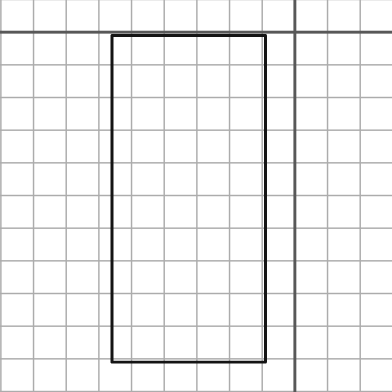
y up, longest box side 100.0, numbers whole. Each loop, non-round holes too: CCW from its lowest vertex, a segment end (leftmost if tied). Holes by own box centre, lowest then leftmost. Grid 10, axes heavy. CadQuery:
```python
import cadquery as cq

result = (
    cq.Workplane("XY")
    .moveTo(-56.0, -101.0)
    .lineTo(-9.0, -101.0)
    .lineTo(-9.0, -1.0)
    .lineTo(-56.0, -1.0)
    .close()
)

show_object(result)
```